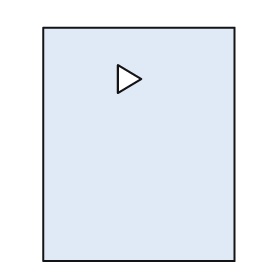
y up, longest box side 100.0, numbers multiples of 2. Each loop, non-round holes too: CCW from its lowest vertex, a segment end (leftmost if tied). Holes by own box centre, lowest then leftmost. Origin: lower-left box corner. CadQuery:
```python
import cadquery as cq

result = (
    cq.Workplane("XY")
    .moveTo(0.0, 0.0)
    .lineTo(82.0, 0.0)
    .lineTo(82.0, 100.0)
    .lineTo(0.0, 100.0)
    .close()
    .moveTo(32.0, 72.0)
    .lineTo(42.0, 78.0)
    .lineTo(32.0, 84.0)
    .close()
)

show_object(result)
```